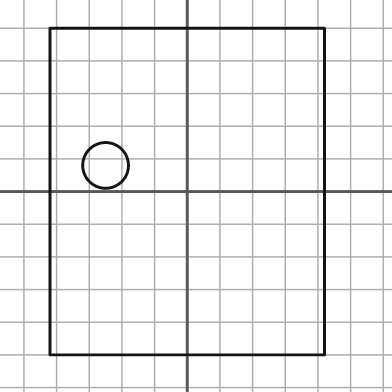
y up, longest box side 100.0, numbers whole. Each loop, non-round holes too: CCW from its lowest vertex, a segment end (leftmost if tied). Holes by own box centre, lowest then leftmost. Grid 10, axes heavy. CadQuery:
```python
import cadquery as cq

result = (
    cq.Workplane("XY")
    .moveTo(-42.0, -50.0)
    .lineTo(42.0, -50.0)
    .lineTo(42.0, 50.0)
    .lineTo(-42.0, 50.0)
    .close()
    .moveTo(-25.0, 8.0)
    .circle(7.0)
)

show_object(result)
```